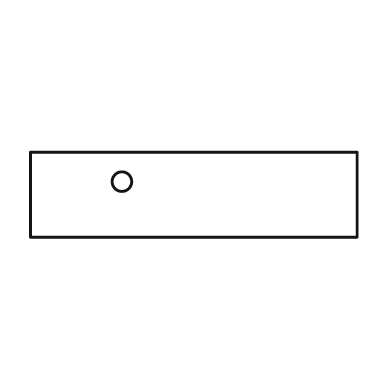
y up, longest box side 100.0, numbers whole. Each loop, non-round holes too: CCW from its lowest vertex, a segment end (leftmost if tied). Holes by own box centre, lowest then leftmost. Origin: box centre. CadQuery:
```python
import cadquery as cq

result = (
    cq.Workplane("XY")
    .moveTo(-50.0, -13.0)
    .lineTo(50.0, -13.0)
    .lineTo(50.0, 13.0)
    .lineTo(-50.0, 13.0)
    .close()
    .moveTo(-22.0, 4.0)
    .circle(3.0)
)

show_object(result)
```